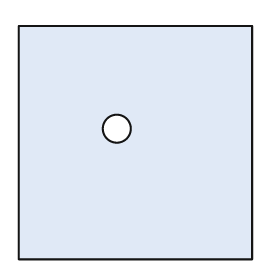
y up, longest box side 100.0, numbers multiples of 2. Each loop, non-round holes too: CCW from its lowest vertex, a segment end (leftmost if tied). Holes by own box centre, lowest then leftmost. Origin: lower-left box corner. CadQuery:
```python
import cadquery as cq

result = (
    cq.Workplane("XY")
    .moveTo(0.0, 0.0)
    .lineTo(100.0, 0.0)
    .lineTo(100.0, 100.0)
    .lineTo(0.0, 100.0)
    .close()
    .moveTo(42.0, 56.0)
    .circle(6.0)
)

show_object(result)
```